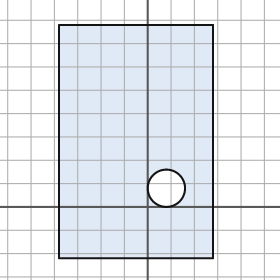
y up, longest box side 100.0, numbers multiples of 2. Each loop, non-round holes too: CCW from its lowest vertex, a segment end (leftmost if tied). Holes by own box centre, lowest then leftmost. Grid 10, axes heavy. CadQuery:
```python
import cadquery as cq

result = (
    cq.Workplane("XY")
    .moveTo(-38.0, -22.0)
    .lineTo(28.0, -22.0)
    .lineTo(28.0, 78.0)
    .lineTo(-38.0, 78.0)
    .close()
    .moveTo(8.0, 8.0)
    .circle(8.0)
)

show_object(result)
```